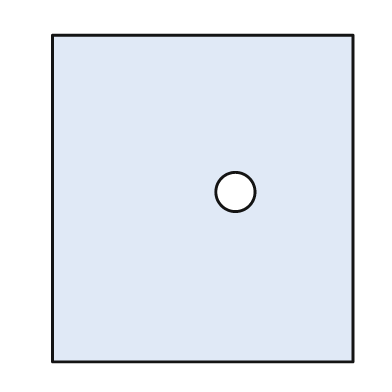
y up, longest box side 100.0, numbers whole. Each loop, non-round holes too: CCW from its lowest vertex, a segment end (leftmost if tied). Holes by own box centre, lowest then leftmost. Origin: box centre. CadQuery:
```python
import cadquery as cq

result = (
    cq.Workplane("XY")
    .moveTo(-46.0, -50.0)
    .lineTo(46.0, -50.0)
    .lineTo(46.0, 50.0)
    .lineTo(-46.0, 50.0)
    .close()
    .moveTo(10.0, 2.0)
    .circle(6.0)
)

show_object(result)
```